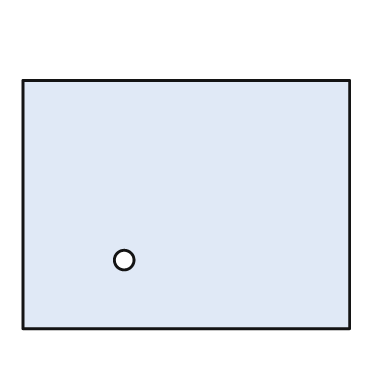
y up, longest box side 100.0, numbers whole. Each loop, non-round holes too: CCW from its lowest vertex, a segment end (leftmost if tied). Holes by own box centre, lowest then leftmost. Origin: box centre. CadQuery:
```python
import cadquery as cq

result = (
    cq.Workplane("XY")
    .moveTo(-50.0, -38.0)
    .lineTo(50.0, -38.0)
    .lineTo(50.0, 38.0)
    .lineTo(-50.0, 38.0)
    .close()
    .moveTo(-19.0, -17.0)
    .circle(3.0)
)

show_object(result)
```